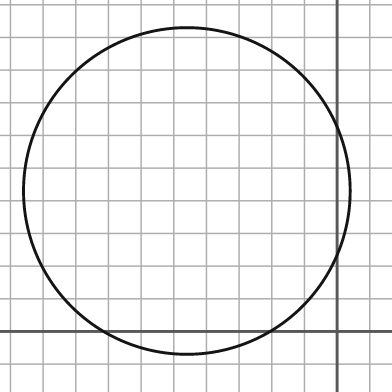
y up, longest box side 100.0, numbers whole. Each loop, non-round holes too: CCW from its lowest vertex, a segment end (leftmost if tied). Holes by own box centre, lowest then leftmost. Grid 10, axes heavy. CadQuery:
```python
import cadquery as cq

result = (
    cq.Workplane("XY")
    .moveTo(-46.0, 43.0)
    .circle(50.0)
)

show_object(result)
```